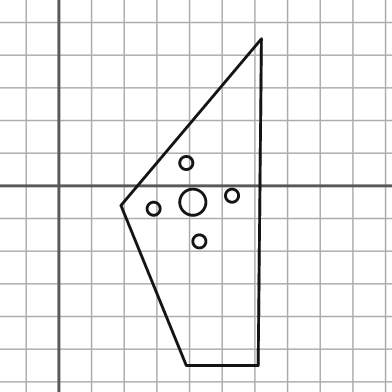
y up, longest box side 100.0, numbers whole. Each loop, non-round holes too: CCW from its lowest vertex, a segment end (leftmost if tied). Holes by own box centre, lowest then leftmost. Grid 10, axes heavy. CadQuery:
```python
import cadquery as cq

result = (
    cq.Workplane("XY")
    .moveTo(39.0, -55.0)
    .lineTo(61.0, -55.0)
    .lineTo(62.0, 45.0)
    .lineTo(19.0, -6.0)
    .close()
    .moveTo(43.0, -17.0)
    .circle(2.0)
    .moveTo(29.0, -7.0)
    .circle(2.0)
    .moveTo(41.0, -5.0)
    .circle(4.0)
    .moveTo(53.0, -3.0)
    .circle(2.0)
    .moveTo(39.0, 7.0)
    .circle(2.0)
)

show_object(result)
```